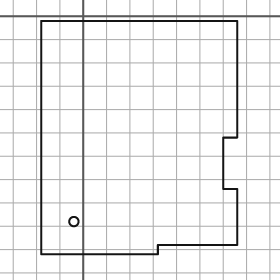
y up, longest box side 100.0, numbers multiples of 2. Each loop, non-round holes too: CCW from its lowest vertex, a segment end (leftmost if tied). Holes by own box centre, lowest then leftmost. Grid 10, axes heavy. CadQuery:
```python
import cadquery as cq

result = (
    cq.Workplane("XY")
    .moveTo(-18.0, -102.0)
    .lineTo(32.0, -102.0)
    .lineTo(32.0, -98.0)
    .lineTo(66.0, -98.0)
    .lineTo(66.0, -74.0)
    .lineTo(60.0, -74.0)
    .lineTo(60.0, -52.0)
    .lineTo(66.0, -52.0)
    .lineTo(66.0, -2.0)
    .lineTo(-18.0, -2.0)
    .close()
    .moveTo(-4.0, -88.0)
    .circle(2.0)
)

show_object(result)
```